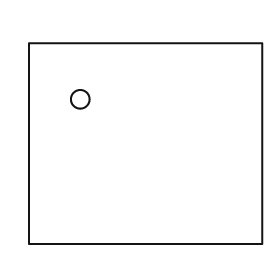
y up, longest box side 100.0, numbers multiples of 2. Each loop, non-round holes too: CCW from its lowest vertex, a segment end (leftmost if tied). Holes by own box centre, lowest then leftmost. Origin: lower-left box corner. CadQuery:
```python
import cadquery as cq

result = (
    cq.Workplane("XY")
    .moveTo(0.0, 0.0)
    .lineTo(100.0, 0.0)
    .lineTo(100.0, 86.0)
    .lineTo(0.0, 86.0)
    .close()
    .moveTo(22.0, 62.0)
    .circle(4.0)
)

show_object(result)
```